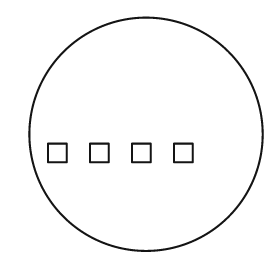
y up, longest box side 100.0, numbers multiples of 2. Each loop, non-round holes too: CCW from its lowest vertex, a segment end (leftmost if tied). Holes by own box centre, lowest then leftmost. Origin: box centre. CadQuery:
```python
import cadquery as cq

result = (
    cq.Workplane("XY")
    .moveTo(0.0, 0.0)
    .circle(50.0)
    .moveTo(-42.0, -12.0)
    .lineTo(-34.0, -12.0)
    .lineTo(-34.0, -4.0)
    .lineTo(-42.0, -4.0)
    .close()
    .moveTo(-24.0, -12.0)
    .lineTo(-16.0, -12.0)
    .lineTo(-16.0, -4.0)
    .lineTo(-24.0, -4.0)
    .close()
    .moveTo(-6.0, -12.0)
    .lineTo(2.0, -12.0)
    .lineTo(2.0, -4.0)
    .lineTo(-6.0, -4.0)
    .close()
    .moveTo(12.0, -12.0)
    .lineTo(20.0, -12.0)
    .lineTo(20.0, -4.0)
    .lineTo(12.0, -4.0)
    .close()
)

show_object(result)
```